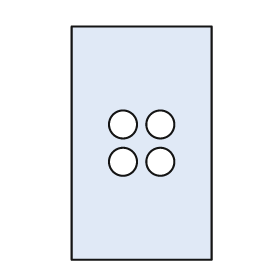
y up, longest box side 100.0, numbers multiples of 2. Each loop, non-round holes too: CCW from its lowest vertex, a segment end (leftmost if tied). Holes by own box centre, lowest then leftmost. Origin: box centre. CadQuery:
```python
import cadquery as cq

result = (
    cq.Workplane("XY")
    .moveTo(-30.0, -50.0)
    .lineTo(30.0, -50.0)
    .lineTo(30.0, 50.0)
    .lineTo(-30.0, 50.0)
    .close()
    .moveTo(-8.0, -8.0)
    .circle(6.0)
    .moveTo(8.0, -8.0)
    .circle(6.0)
    .moveTo(-8.0, 8.0)
    .circle(6.0)
    .moveTo(8.0, 8.0)
    .circle(6.0)
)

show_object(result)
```